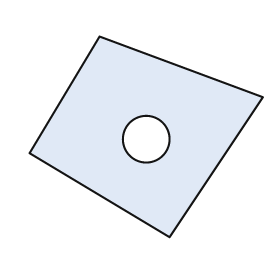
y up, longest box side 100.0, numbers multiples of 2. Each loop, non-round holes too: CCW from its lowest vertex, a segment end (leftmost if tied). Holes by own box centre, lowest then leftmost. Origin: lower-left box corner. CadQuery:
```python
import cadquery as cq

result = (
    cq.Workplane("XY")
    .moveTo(60.0, 0.0)
    .lineTo(100.0, 60.0)
    .lineTo(30.0, 86.0)
    .lineTo(0.0, 36.0)
    .close()
    .moveTo(50.0, 42.0)
    .circle(10.0)
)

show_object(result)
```